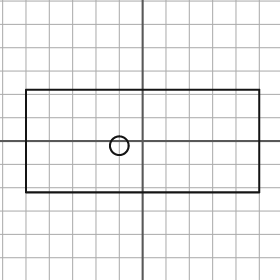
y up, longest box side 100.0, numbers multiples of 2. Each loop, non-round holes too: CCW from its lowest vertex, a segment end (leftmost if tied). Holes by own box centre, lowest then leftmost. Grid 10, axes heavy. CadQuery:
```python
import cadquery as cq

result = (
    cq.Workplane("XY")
    .moveTo(-50.0, -22.0)
    .lineTo(50.0, -22.0)
    .lineTo(50.0, 22.0)
    .lineTo(-50.0, 22.0)
    .close()
    .moveTo(-10.0, -2.0)
    .circle(4.0)
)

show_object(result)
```